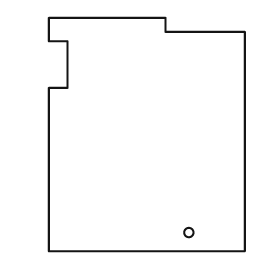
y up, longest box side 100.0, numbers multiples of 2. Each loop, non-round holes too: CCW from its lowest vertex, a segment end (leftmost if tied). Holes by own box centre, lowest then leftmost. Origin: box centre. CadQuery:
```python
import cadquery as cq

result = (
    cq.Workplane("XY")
    .moveTo(-42.0, -50.0)
    .lineTo(42.0, -50.0)
    .lineTo(42.0, 44.0)
    .lineTo(8.0, 44.0)
    .lineTo(8.0, 50.0)
    .lineTo(-42.0, 50.0)
    .lineTo(-42.0, 40.0)
    .lineTo(-34.0, 40.0)
    .lineTo(-34.0, 20.0)
    .lineTo(-42.0, 20.0)
    .close()
    .moveTo(18.0, -42.0)
    .circle(2.0)
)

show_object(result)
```